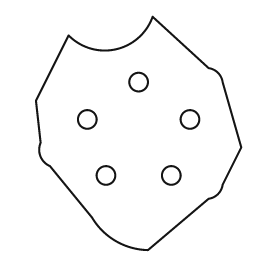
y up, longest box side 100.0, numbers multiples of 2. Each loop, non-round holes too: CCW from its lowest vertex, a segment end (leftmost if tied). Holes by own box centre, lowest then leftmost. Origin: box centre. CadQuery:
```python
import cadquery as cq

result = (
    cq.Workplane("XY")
    .moveTo(4.0, -50.0)
    .lineTo(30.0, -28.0)
    .threePointArc((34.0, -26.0), (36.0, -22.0))
    .lineTo(44.0, -6.0)
    .lineTo(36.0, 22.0)
    .threePointArc((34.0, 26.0), (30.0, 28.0))
    .lineTo(6.0, 50.0)
    .threePointArc((-10.0, 36.0), (-30.0, 42.0))
    .lineTo(-44.0, 14.0)
    .lineTo(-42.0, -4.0)
    .threePointArc((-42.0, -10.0), (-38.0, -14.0))
    .lineTo(-20.0, -36.0)
    .threePointArc((-10.0, -46.0), (4.0, -50.0))
    .close()
    .moveTo(-14.0, -18.0)
    .circle(4.0)
    .moveTo(14.0, -18.0)
    .circle(4.0)
    .moveTo(-22.0, 6.0)
    .circle(4.0)
    .moveTo(22.0, 6.0)
    .circle(4.0)
    .moveTo(0.0, 22.0)
    .circle(4.0)
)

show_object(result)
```